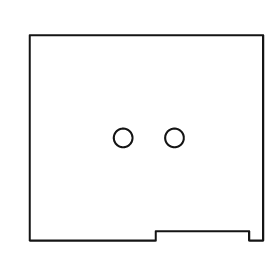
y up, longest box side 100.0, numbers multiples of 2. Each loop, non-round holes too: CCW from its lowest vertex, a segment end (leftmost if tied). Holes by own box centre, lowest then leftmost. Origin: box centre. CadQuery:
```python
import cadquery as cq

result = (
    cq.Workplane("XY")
    .moveTo(-50.0, -44.0)
    .lineTo(4.0, -44.0)
    .lineTo(4.0, -40.0)
    .lineTo(44.0, -40.0)
    .lineTo(44.0, -44.0)
    .lineTo(50.0, -44.0)
    .lineTo(50.0, 44.0)
    .lineTo(-50.0, 44.0)
    .close()
    .moveTo(-10.0, 0.0)
    .circle(4.0)
    .moveTo(12.0, 0.0)
    .circle(4.0)
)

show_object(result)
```